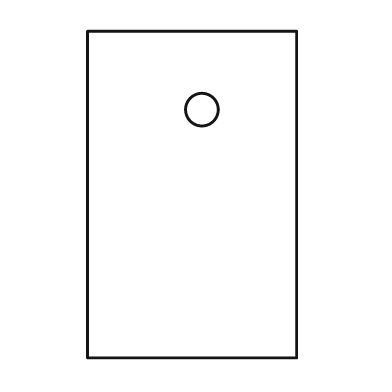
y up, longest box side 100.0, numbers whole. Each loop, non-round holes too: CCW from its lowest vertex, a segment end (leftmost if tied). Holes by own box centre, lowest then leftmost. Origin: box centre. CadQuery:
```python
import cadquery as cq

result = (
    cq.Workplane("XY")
    .moveTo(-32.0, -50.0)
    .lineTo(32.0, -50.0)
    .lineTo(32.0, 50.0)
    .lineTo(-32.0, 50.0)
    .close()
    .moveTo(3.0, 26.0)
    .circle(5.0)
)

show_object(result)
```